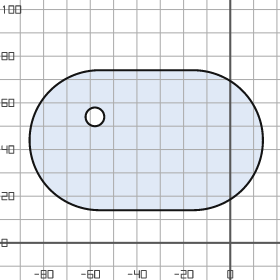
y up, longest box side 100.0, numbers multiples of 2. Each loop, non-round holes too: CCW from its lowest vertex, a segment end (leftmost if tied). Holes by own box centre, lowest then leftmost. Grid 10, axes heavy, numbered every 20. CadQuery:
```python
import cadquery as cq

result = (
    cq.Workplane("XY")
    .moveTo(-56.0, 14.0)
    .lineTo(-16.0, 14.0)
    .threePointArc((14.0, 44.0), (-16.0, 74.0))
    .lineTo(-56.0, 74.0)
    .threePointArc((-86.0, 44.0), (-56.0, 14.0))
    .close()
    .moveTo(-58.0, 54.0)
    .circle(4.0)
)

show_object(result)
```